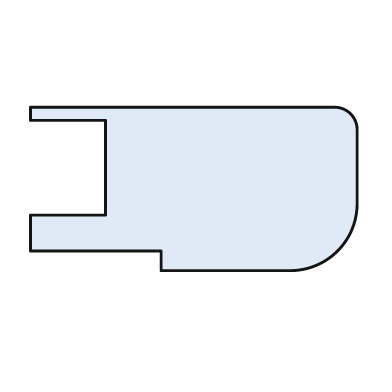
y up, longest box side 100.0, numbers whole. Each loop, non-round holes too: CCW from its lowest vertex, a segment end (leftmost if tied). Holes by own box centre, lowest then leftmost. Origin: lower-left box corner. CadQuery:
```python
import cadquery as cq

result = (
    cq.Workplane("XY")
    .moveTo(40.0, 0.0)
    .lineTo(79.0, 0.0)
    .threePointArc((94.0, 6.0), (100.0, 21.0))
    .lineTo(100.0, 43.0)
    .threePointArc((98.0, 48.0), (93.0, 50.0))
    .lineTo(0.0, 50.0)
    .lineTo(0.0, 46.0)
    .lineTo(23.0, 46.0)
    .lineTo(23.0, 17.0)
    .lineTo(0.0, 17.0)
    .lineTo(0.0, 6.0)
    .lineTo(40.0, 6.0)
    .close()
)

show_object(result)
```